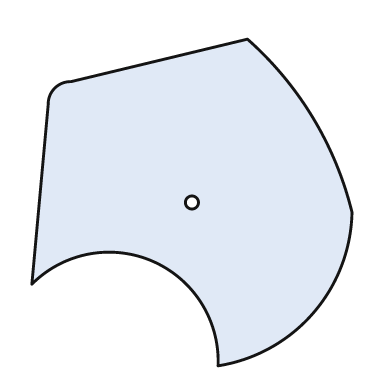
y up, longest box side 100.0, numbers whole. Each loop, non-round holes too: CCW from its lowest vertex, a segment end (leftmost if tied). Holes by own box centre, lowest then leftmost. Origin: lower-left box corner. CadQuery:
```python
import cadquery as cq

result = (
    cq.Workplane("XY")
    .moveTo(57.0, 0.0)
    .threePointArc((86.0, 16.0), (98.0, 47.0))
    .threePointArc((86.0, 76.0), (66.0, 100.0))
    .lineTo(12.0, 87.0)
    .threePointArc((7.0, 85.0), (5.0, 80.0))
    .lineTo(0.0, 25.0)
    .threePointArc((37.0, 32.0), (57.0, 0.0))
    .close()
    .moveTo(49.0, 50.0)
    .circle(2.0)
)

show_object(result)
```